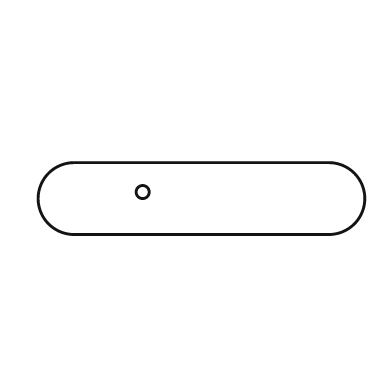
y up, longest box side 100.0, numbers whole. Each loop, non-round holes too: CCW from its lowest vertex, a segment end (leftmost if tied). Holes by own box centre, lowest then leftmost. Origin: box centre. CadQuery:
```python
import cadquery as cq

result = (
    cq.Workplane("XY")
    .moveTo(-39.0, -11.0)
    .lineTo(39.0, -11.0)
    .threePointArc((50.0, 0.0), (39.0, 11.0))
    .lineTo(-39.0, 11.0)
    .threePointArc((-50.0, 0.0), (-39.0, -11.0))
    .close()
    .moveTo(-18.0, 2.0)
    .circle(2.0)
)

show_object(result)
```